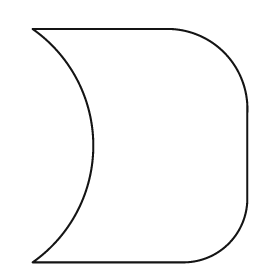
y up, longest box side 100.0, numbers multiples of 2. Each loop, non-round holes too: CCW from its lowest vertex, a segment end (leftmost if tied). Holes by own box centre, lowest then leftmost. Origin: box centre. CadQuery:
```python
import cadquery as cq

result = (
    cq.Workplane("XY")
    .moveTo(-46.0, -50.0)
    .lineTo(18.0, -50.0)
    .threePointArc((38.0, -42.0), (46.0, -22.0))
    .lineTo(46.0, 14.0)
    .threePointArc((36.0, 40.0), (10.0, 50.0))
    .lineTo(-46.0, 50.0)
    .threePointArc((-20.0, 0.0), (-46.0, -50.0))
    .close()
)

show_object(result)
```